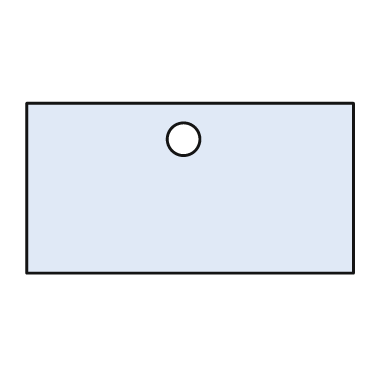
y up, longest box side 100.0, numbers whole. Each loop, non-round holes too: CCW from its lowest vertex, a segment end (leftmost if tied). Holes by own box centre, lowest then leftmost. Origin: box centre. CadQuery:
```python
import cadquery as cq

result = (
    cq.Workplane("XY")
    .moveTo(-50.0, -26.0)
    .lineTo(50.0, -26.0)
    .lineTo(50.0, 26.0)
    .lineTo(-50.0, 26.0)
    .close()
    .moveTo(-2.0, 15.0)
    .circle(5.0)
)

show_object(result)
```